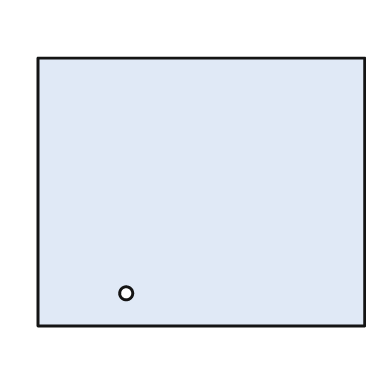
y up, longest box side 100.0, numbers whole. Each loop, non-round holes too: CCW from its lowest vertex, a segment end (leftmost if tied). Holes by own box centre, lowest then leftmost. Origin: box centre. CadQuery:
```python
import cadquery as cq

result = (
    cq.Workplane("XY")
    .moveTo(-50.0, -41.0)
    .lineTo(50.0, -41.0)
    .lineTo(50.0, 41.0)
    .lineTo(-50.0, 41.0)
    .close()
    .moveTo(-23.0, -31.0)
    .circle(2.0)
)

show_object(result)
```